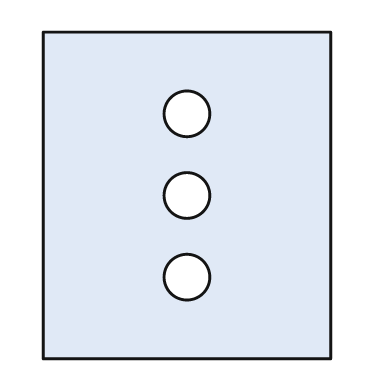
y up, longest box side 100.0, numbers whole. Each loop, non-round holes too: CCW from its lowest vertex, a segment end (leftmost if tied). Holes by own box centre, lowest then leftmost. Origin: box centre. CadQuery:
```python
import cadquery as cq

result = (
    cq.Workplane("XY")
    .moveTo(-44.0, -50.0)
    .lineTo(44.0, -50.0)
    .lineTo(44.0, 50.0)
    .lineTo(-44.0, 50.0)
    .close()
    .moveTo(0.0, -25.0)
    .circle(7.0)
    .moveTo(0.0, 0.0)
    .circle(7.0)
    .moveTo(0.0, 25.0)
    .circle(7.0)
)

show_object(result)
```